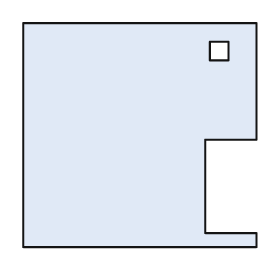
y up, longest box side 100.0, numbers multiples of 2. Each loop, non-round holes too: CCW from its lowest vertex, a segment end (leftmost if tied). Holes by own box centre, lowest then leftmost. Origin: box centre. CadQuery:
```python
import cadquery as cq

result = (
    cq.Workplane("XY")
    .moveTo(-50.0, -48.0)
    .lineTo(50.0, -48.0)
    .lineTo(50.0, -42.0)
    .lineTo(28.0, -42.0)
    .lineTo(28.0, -2.0)
    .lineTo(50.0, -2.0)
    .lineTo(50.0, 48.0)
    .lineTo(-50.0, 48.0)
    .close()
    .moveTo(30.0, 32.0)
    .lineTo(38.0, 32.0)
    .lineTo(38.0, 40.0)
    .lineTo(30.0, 40.0)
    .close()
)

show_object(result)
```